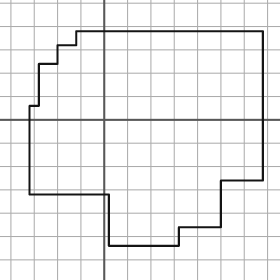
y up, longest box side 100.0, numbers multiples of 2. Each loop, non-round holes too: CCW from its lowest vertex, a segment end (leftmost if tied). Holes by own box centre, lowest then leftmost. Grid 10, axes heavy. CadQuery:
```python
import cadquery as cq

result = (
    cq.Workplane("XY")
    .moveTo(2.0, -54.0)
    .lineTo(32.0, -54.0)
    .lineTo(32.0, -46.0)
    .lineTo(50.0, -46.0)
    .lineTo(50.0, -26.0)
    .lineTo(68.0, -26.0)
    .lineTo(68.0, 38.0)
    .lineTo(-12.0, 38.0)
    .lineTo(-12.0, 32.0)
    .lineTo(-20.0, 32.0)
    .lineTo(-20.0, 24.0)
    .lineTo(-28.0, 24.0)
    .lineTo(-28.0, 6.0)
    .lineTo(-32.0, 6.0)
    .lineTo(-32.0, -32.0)
    .lineTo(2.0, -32.0)
    .close()
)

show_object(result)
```